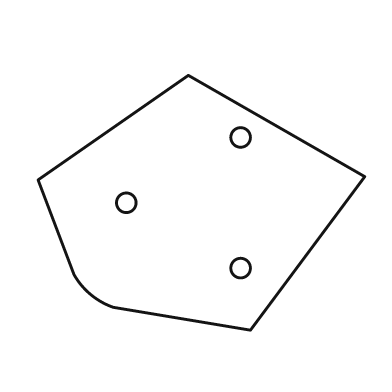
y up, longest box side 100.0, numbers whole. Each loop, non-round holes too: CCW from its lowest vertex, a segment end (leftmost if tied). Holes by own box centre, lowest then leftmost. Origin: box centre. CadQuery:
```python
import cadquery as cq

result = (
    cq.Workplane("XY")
    .moveTo(15.0, -39.0)
    .lineTo(50.0, 8.0)
    .lineTo(-4.0, 39.0)
    .lineTo(-50.0, 7.0)
    .lineTo(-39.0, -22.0)
    .threePointArc((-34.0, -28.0), (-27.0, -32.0))
    .close()
    .moveTo(12.0, -20.0)
    .circle(3.0)
    .moveTo(-23.0, 0.0)
    .circle(3.0)
    .moveTo(12.0, 20.0)
    .circle(3.0)
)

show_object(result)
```